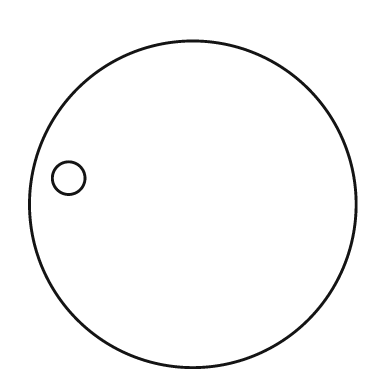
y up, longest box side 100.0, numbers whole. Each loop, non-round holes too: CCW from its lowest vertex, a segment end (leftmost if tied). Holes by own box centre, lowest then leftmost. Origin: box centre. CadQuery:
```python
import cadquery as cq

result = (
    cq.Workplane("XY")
    .moveTo(0.0, 0.0)
    .circle(50.0)
    .moveTo(-38.0, 8.0)
    .circle(5.0)
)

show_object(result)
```